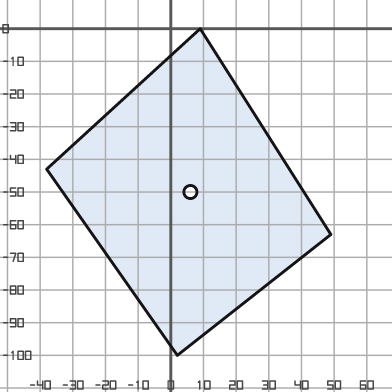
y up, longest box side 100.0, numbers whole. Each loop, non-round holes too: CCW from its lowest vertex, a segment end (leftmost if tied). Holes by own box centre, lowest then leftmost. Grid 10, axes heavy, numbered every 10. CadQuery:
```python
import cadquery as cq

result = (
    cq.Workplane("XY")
    .moveTo(2.0, -100.0)
    .lineTo(49.0, -63.0)
    .lineTo(9.0, 0.0)
    .lineTo(-38.0, -43.0)
    .close()
    .moveTo(6.0, -50.0)
    .circle(2.0)
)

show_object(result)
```